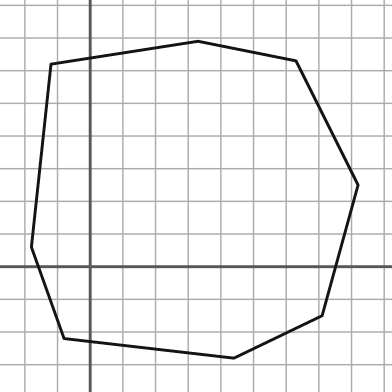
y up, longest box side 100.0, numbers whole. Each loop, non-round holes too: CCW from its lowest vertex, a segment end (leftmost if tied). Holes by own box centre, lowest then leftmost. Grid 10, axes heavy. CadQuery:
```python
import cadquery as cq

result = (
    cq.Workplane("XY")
    .moveTo(44.0, -28.0)
    .lineTo(71.0, -15.0)
    .lineTo(82.0, 25.0)
    .lineTo(63.0, 63.0)
    .lineTo(33.0, 69.0)
    .lineTo(-12.0, 62.0)
    .lineTo(-18.0, 6.0)
    .lineTo(-8.0, -22.0)
    .close()
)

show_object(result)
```